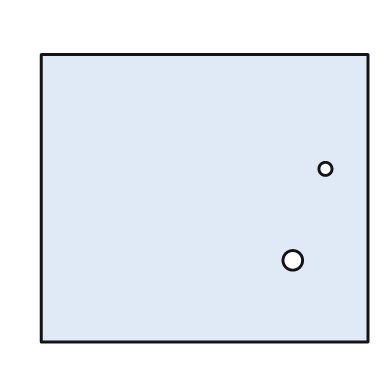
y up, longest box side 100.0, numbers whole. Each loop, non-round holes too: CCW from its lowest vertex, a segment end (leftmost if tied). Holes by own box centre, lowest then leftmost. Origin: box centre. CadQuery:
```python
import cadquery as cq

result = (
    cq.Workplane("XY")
    .moveTo(-50.0, -44.0)
    .lineTo(50.0, -44.0)
    .lineTo(50.0, 44.0)
    .lineTo(-50.0, 44.0)
    .close()
    .moveTo(27.0, -19.0)
    .circle(3.0)
    .moveTo(37.0, 9.0)
    .circle(2.0)
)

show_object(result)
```